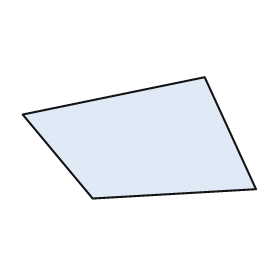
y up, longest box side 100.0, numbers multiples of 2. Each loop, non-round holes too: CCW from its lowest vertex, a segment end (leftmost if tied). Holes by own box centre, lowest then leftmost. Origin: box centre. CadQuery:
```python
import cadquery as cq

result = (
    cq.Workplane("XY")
    .moveTo(-20.0, -26.0)
    .lineTo(50.0, -22.0)
    .lineTo(28.0, 26.0)
    .lineTo(-50.0, 10.0)
    .close()
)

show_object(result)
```